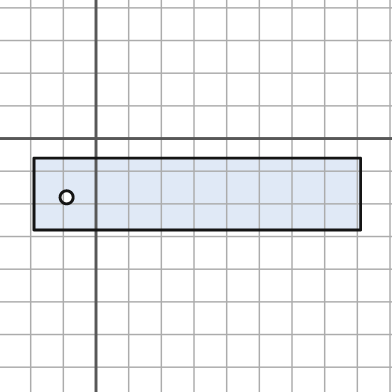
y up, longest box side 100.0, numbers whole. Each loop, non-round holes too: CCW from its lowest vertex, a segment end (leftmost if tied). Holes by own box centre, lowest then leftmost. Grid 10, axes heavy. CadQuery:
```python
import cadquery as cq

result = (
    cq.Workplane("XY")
    .moveTo(-19.0, -28.0)
    .lineTo(81.0, -28.0)
    .lineTo(81.0, -6.0)
    .lineTo(-19.0, -6.0)
    .close()
    .moveTo(-9.0, -18.0)
    .circle(2.0)
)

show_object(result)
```